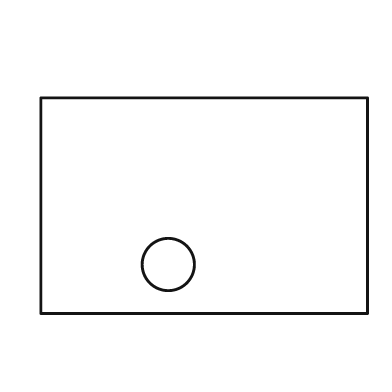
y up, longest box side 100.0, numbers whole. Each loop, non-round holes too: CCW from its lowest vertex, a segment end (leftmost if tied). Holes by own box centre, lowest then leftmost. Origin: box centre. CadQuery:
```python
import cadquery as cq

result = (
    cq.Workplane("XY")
    .moveTo(-50.0, -33.0)
    .lineTo(50.0, -33.0)
    .lineTo(50.0, 33.0)
    .lineTo(-50.0, 33.0)
    .close()
    .moveTo(-11.0, -18.0)
    .circle(8.0)
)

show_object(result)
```